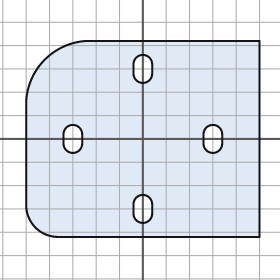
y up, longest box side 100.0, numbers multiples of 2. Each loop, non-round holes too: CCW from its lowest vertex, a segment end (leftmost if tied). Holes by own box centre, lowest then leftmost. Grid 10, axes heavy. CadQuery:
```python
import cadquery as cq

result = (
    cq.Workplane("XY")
    .moveTo(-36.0, -42.0)
    .lineTo(50.0, -42.0)
    .lineTo(50.0, 42.0)
    .lineTo(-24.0, 42.0)
    .threePointArc((-42.0, 34.0), (-50.0, 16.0))
    .lineTo(-50.0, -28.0)
    .threePointArc((-46.0, -38.0), (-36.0, -42.0))
    .close()
    .moveTo(-4.0, -32.0)
    .threePointArc((0.0, -36.0), (4.0, -32.0))
    .lineTo(4.0, -28.0)
    .threePointArc((0.0, -24.0), (-4.0, -28.0))
    .close()
    .moveTo(-34.0, -2.0)
    .threePointArc((-30.0, -6.0), (-26.0, -2.0))
    .lineTo(-26.0, 2.0)
    .threePointArc((-30.0, 6.0), (-34.0, 2.0))
    .close()
    .moveTo(26.0, -2.0)
    .threePointArc((30.0, -6.0), (34.0, -2.0))
    .lineTo(34.0, 2.0)
    .threePointArc((30.0, 6.0), (26.0, 2.0))
    .close()
    .moveTo(-4.0, 28.0)
    .threePointArc((0.0, 24.0), (4.0, 28.0))
    .lineTo(4.0, 32.0)
    .threePointArc((0.0, 36.0), (-4.0, 32.0))
    .close()
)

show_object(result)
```